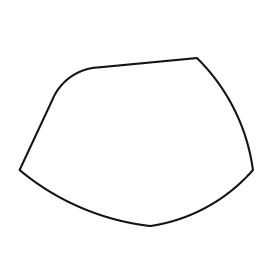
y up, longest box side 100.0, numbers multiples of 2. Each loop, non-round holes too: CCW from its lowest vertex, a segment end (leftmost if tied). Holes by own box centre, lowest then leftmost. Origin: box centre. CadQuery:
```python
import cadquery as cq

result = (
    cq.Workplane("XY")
    .moveTo(6.0, -36.0)
    .threePointArc((30.0, -28.0), (50.0, -12.0))
    .threePointArc((42.0, 14.0), (26.0, 36.0))
    .lineTo(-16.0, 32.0)
    .threePointArc((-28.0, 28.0), (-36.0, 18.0))
    .lineTo(-50.0, -12.0)
    .threePointArc((-24.0, -28.0), (6.0, -36.0))
    .close()
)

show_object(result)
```